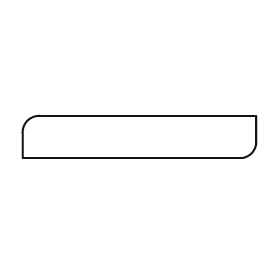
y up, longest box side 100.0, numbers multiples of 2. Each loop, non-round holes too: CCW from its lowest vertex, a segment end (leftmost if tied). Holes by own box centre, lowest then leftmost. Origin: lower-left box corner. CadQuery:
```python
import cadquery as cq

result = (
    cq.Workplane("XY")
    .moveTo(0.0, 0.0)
    .lineTo(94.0, 0.0)
    .threePointArc((98.0, 2.0), (100.0, 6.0))
    .lineTo(100.0, 18.0)
    .lineTo(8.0, 18.0)
    .threePointArc((2.0, 16.0), (0.0, 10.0))
    .close()
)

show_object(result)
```